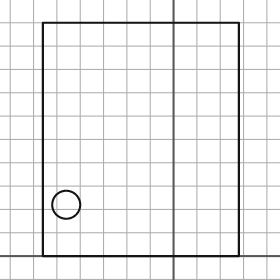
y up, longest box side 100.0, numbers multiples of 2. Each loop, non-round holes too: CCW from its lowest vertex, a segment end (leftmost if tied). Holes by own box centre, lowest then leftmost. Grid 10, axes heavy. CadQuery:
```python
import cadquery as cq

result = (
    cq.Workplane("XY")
    .moveTo(-56.0, 0.0)
    .lineTo(28.0, 0.0)
    .lineTo(28.0, 100.0)
    .lineTo(-56.0, 100.0)
    .close()
    .moveTo(-46.0, 22.0)
    .circle(6.0)
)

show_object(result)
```